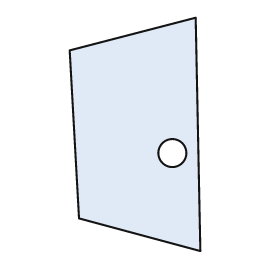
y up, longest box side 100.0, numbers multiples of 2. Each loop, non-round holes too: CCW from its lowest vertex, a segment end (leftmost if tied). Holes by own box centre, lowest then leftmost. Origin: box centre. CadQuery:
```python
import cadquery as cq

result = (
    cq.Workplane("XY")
    .moveTo(28.0, -50.0)
    .lineTo(26.0, 50.0)
    .lineTo(-28.0, 36.0)
    .lineTo(-24.0, -36.0)
    .close()
    .moveTo(16.0, -8.0)
    .circle(6.0)
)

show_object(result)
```